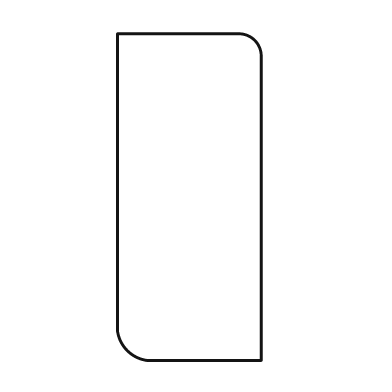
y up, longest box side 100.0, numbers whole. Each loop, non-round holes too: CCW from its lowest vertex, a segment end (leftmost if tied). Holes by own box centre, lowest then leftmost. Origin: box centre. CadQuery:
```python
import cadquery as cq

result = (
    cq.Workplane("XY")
    .moveTo(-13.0, -50.0)
    .lineTo(22.0, -50.0)
    .lineTo(22.0, 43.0)
    .threePointArc((20.0, 48.0), (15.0, 50.0))
    .lineTo(-22.0, 50.0)
    .lineTo(-22.0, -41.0)
    .threePointArc((-19.0, -47.0), (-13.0, -50.0))
    .close()
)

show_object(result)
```